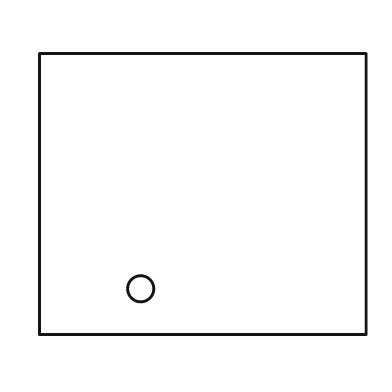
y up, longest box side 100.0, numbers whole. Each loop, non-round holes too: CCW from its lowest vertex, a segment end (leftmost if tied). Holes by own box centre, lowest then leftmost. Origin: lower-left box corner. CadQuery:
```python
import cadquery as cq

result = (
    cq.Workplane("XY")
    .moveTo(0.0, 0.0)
    .lineTo(100.0, 0.0)
    .lineTo(100.0, 86.0)
    .lineTo(0.0, 86.0)
    .close()
    .moveTo(31.0, 14.0)
    .circle(4.0)
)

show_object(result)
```